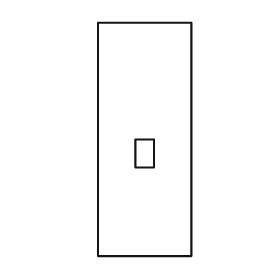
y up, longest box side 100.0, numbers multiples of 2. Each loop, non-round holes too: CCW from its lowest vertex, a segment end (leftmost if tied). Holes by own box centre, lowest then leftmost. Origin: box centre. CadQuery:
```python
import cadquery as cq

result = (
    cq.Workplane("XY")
    .moveTo(-20.0, -50.0)
    .lineTo(20.0, -50.0)
    .lineTo(20.0, 50.0)
    .lineTo(-20.0, 50.0)
    .close()
    .moveTo(-4.0, -12.0)
    .lineTo(4.0, -12.0)
    .lineTo(4.0, 0.0)
    .lineTo(-4.0, 0.0)
    .close()
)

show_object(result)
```